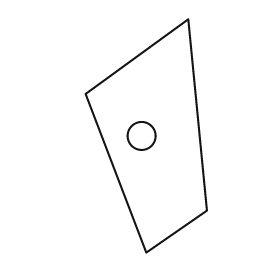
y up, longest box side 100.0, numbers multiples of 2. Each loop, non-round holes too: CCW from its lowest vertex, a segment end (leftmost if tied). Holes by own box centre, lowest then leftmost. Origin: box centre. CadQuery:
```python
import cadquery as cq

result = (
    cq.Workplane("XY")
    .moveTo(0.0, -50.0)
    .lineTo(26.0, -32.0)
    .lineTo(18.0, 50.0)
    .lineTo(-26.0, 18.0)
    .close()
    .moveTo(-2.0, 0.0)
    .circle(6.0)
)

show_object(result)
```